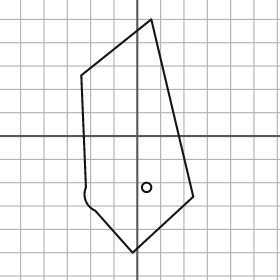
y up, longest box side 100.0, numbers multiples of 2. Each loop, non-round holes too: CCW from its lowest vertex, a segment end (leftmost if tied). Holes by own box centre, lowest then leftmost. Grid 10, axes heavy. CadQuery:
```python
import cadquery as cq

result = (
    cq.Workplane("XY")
    .moveTo(-2.0, -50.0)
    .lineTo(24.0, -26.0)
    .lineTo(6.0, 50.0)
    .lineTo(-24.0, 26.0)
    .lineTo(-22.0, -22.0)
    .threePointArc((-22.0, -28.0), (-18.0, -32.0))
    .close()
    .moveTo(4.0, -22.0)
    .circle(2.0)
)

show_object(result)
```